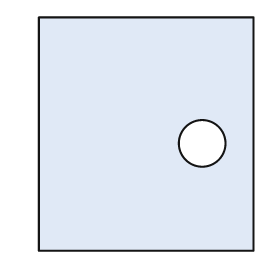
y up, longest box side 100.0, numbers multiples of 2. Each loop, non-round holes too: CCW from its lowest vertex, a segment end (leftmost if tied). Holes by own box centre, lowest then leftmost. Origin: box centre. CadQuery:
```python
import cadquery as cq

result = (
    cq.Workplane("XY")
    .moveTo(-46.0, -50.0)
    .lineTo(46.0, -50.0)
    .lineTo(46.0, 50.0)
    .lineTo(-46.0, 50.0)
    .close()
    .moveTo(24.0, -4.0)
    .circle(10.0)
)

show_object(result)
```